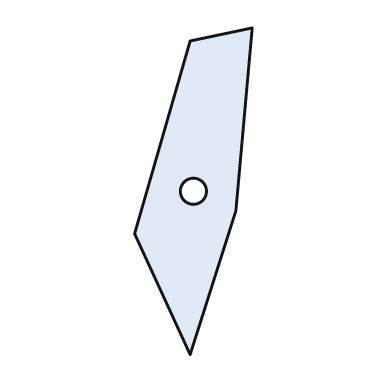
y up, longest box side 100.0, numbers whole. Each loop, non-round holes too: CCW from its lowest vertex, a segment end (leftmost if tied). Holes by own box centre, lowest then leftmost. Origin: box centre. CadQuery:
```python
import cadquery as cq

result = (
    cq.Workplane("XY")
    .moveTo(-1.0, -50.0)
    .lineTo(13.0, -6.0)
    .lineTo(18.0, 50.0)
    .lineTo(-1.0, 46.0)
    .lineTo(-18.0, -13.0)
    .close()
    .moveTo(0.0, 0.0)
    .circle(4.0)
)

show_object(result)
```